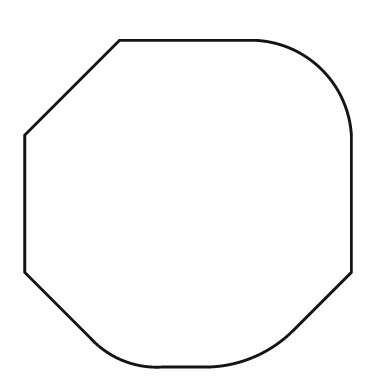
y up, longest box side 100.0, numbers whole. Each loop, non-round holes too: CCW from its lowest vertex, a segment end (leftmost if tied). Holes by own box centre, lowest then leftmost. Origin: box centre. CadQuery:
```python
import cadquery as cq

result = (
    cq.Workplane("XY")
    .moveTo(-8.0, -50.0)
    .lineTo(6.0, -50.0)
    .threePointArc((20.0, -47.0), (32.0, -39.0))
    .lineTo(50.0, -21.0)
    .lineTo(50.0, 21.0)
    .threePointArc((41.0, 41.0), (21.0, 50.0))
    .lineTo(-21.0, 50.0)
    .lineTo(-50.0, 21.0)
    .lineTo(-50.0, -21.0)
    .lineTo(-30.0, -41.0)
    .threePointArc((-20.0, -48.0), (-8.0, -50.0))
    .close()
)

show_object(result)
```